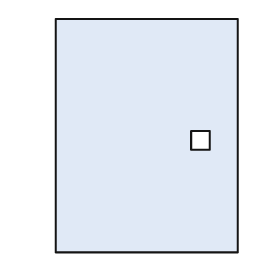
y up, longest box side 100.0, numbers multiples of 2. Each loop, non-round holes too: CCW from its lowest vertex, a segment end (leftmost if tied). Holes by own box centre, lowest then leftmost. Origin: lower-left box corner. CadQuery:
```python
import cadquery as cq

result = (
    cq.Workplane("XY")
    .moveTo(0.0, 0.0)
    .lineTo(78.0, 0.0)
    .lineTo(78.0, 100.0)
    .lineTo(0.0, 100.0)
    .close()
    .moveTo(58.0, 44.0)
    .lineTo(66.0, 44.0)
    .lineTo(66.0, 52.0)
    .lineTo(58.0, 52.0)
    .close()
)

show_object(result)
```